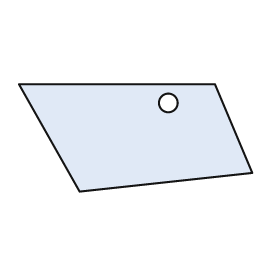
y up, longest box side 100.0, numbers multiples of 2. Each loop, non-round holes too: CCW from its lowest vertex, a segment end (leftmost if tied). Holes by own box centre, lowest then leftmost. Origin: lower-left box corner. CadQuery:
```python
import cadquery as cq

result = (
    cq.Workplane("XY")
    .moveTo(26.0, 0.0)
    .lineTo(100.0, 8.0)
    .lineTo(84.0, 46.0)
    .lineTo(0.0, 46.0)
    .close()
    .moveTo(64.0, 38.0)
    .circle(4.0)
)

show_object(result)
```